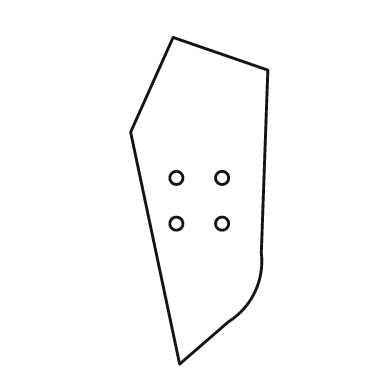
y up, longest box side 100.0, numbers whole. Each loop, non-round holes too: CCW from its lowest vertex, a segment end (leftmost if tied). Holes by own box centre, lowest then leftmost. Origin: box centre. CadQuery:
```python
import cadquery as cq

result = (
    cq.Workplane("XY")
    .moveTo(-6.0, -50.0)
    .lineTo(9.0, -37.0)
    .threePointArc((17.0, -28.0), (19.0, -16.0))
    .lineTo(21.0, 40.0)
    .lineTo(-8.0, 50.0)
    .lineTo(-21.0, 21.0)
    .close()
    .moveTo(-7.0, -7.0)
    .circle(2.0)
    .moveTo(7.0, -7.0)
    .circle(2.0)
    .moveTo(-7.0, 7.0)
    .circle(2.0)
    .moveTo(7.0, 7.0)
    .circle(2.0)
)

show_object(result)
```